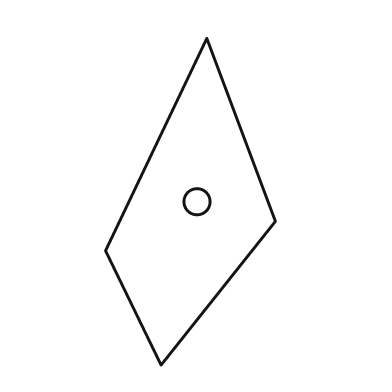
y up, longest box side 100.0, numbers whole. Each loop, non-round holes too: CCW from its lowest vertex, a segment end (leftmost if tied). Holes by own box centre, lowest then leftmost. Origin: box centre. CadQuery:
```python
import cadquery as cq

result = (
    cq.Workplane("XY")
    .moveTo(-9.0, -50.0)
    .lineTo(26.0, -6.0)
    .lineTo(5.0, 50.0)
    .lineTo(-26.0, -15.0)
    .close()
    .moveTo(2.0, 0.0)
    .circle(4.0)
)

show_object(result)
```